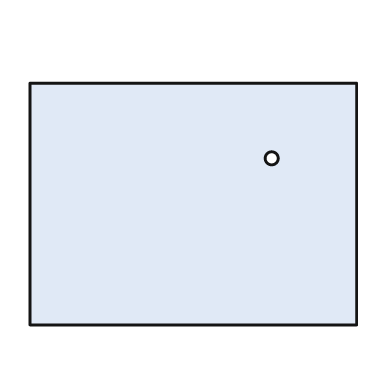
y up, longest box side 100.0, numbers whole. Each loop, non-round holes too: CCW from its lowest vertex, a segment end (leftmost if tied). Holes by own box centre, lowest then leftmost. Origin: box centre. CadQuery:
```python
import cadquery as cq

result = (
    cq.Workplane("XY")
    .moveTo(-50.0, -37.0)
    .lineTo(50.0, -37.0)
    .lineTo(50.0, 37.0)
    .lineTo(-50.0, 37.0)
    .close()
    .moveTo(24.0, 14.0)
    .circle(2.0)
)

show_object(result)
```